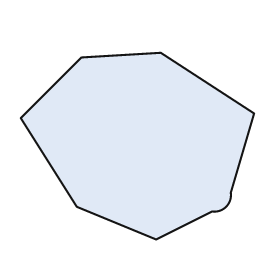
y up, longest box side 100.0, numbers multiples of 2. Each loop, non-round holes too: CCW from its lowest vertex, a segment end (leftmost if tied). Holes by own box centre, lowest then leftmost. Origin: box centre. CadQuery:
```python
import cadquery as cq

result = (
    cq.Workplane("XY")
    .moveTo(8.0, -40.0)
    .lineTo(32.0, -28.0)
    .threePointArc((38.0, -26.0), (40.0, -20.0))
    .lineTo(50.0, 14.0)
    .lineTo(10.0, 40.0)
    .lineTo(-24.0, 38.0)
    .lineTo(-50.0, 12.0)
    .lineTo(-26.0, -26.0)
    .close()
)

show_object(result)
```